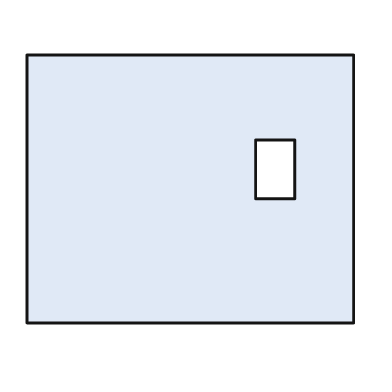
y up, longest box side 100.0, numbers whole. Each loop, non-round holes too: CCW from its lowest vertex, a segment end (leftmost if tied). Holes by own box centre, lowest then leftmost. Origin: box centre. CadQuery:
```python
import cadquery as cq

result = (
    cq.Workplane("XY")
    .moveTo(-50.0, -41.0)
    .lineTo(50.0, -41.0)
    .lineTo(50.0, 41.0)
    .lineTo(-50.0, 41.0)
    .close()
    .moveTo(20.0, -3.0)
    .lineTo(32.0, -3.0)
    .lineTo(32.0, 15.0)
    .lineTo(20.0, 15.0)
    .close()
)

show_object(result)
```